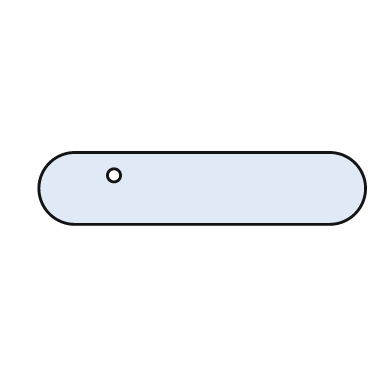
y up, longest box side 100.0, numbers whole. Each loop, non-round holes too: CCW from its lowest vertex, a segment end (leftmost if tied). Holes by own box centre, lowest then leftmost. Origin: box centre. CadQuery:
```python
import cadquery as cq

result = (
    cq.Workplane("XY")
    .moveTo(-39.0, -11.0)
    .lineTo(39.0, -11.0)
    .threePointArc((50.0, 0.0), (39.0, 11.0))
    .lineTo(-39.0, 11.0)
    .threePointArc((-50.0, 0.0), (-39.0, -11.0))
    .close()
    .moveTo(-27.0, 4.0)
    .circle(2.0)
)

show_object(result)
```